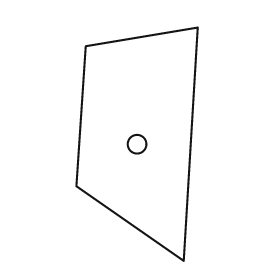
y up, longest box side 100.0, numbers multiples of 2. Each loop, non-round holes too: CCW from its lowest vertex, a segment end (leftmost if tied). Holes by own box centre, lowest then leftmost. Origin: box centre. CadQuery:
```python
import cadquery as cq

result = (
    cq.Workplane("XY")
    .moveTo(20.0, -50.0)
    .lineTo(26.0, 50.0)
    .lineTo(-22.0, 42.0)
    .lineTo(-26.0, -18.0)
    .close()
    .moveTo(0.0, 0.0)
    .circle(4.0)
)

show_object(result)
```